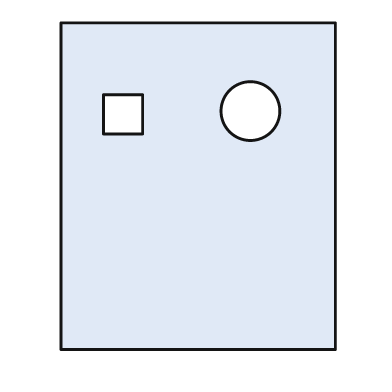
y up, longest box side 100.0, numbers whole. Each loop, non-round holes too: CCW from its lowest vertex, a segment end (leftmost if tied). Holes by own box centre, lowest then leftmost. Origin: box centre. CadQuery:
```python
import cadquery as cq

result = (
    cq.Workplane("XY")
    .moveTo(-42.0, -50.0)
    .lineTo(42.0, -50.0)
    .lineTo(42.0, 50.0)
    .lineTo(-42.0, 50.0)
    .close()
    .moveTo(-29.0, 16.0)
    .lineTo(-17.0, 16.0)
    .lineTo(-17.0, 28.0)
    .lineTo(-29.0, 28.0)
    .close()
    .moveTo(16.0, 23.0)
    .circle(9.0)
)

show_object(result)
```